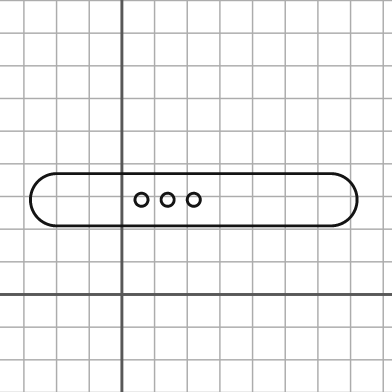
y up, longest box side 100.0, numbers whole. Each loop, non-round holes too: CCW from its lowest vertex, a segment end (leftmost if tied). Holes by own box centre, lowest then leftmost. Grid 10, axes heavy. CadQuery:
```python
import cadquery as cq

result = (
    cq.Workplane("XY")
    .moveTo(-20.0, 21.0)
    .lineTo(64.0, 21.0)
    .threePointArc((72.0, 29.0), (64.0, 37.0))
    .lineTo(-20.0, 37.0)
    .threePointArc((-28.0, 29.0), (-20.0, 21.0))
    .close()
    .moveTo(6.0, 29.0)
    .circle(2.0)
    .moveTo(14.0, 29.0)
    .circle(2.0)
    .moveTo(22.0, 29.0)
    .circle(2.0)
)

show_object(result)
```